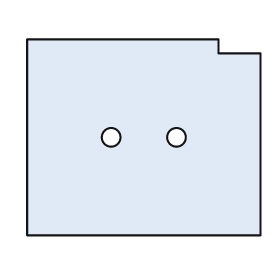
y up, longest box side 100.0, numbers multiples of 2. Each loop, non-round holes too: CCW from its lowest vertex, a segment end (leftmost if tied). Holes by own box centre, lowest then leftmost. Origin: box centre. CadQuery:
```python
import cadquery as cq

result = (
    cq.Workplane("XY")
    .moveTo(-50.0, -42.0)
    .lineTo(50.0, -42.0)
    .lineTo(50.0, 36.0)
    .lineTo(32.0, 36.0)
    .lineTo(32.0, 42.0)
    .lineTo(-50.0, 42.0)
    .close()
    .moveTo(-14.0, 0.0)
    .circle(4.0)
    .moveTo(14.0, 0.0)
    .circle(4.0)
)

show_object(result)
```